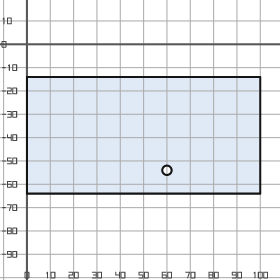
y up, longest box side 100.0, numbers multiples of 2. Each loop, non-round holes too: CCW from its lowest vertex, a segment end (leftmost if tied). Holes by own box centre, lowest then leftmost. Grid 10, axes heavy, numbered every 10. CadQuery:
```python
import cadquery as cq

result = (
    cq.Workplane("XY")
    .moveTo(0.0, -64.0)
    .lineTo(100.0, -64.0)
    .lineTo(100.0, -14.0)
    .lineTo(0.0, -14.0)
    .close()
    .moveTo(60.0, -54.0)
    .circle(2.0)
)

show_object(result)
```